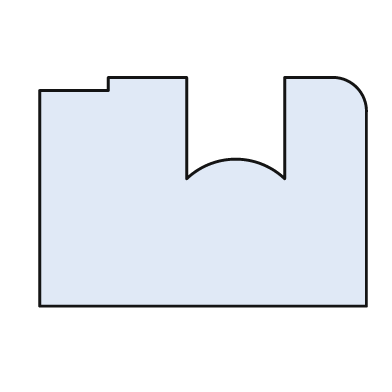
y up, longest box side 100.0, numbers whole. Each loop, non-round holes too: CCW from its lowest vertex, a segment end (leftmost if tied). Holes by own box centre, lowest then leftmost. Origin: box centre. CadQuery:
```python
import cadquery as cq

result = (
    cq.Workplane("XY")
    .moveTo(-50.0, -35.0)
    .lineTo(50.0, -35.0)
    .lineTo(50.0, 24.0)
    .threePointArc((47.0, 32.0), (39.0, 35.0))
    .lineTo(25.0, 35.0)
    .lineTo(25.0, 4.0)
    .threePointArc((10.0, 10.0), (-5.0, 4.0))
    .lineTo(-5.0, 35.0)
    .lineTo(-29.0, 35.0)
    .lineTo(-29.0, 31.0)
    .lineTo(-50.0, 31.0)
    .close()
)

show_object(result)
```